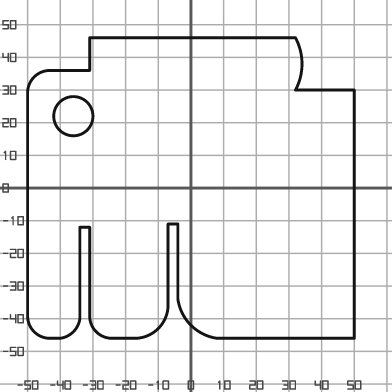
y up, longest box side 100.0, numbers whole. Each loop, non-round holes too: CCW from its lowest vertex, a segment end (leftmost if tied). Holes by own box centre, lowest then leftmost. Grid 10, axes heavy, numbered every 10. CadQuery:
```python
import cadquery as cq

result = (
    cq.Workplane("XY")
    .moveTo(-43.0, -46.0)
    .lineTo(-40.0, -46.0)
    .threePointArc((-36.0, -44.0), (-34.0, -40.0))
    .lineTo(-34.0, -12.0)
    .lineTo(-31.0, -12.0)
    .lineTo(-31.0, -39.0)
    .threePointArc((-29.0, -44.0), (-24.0, -46.0))
    .lineTo(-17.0, -46.0)
    .threePointArc((-10.0, -43.0), (-7.0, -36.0))
    .lineTo(-7.0, -11.0)
    .lineTo(-4.0, -11.0)
    .lineTo(-4.0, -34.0)
    .threePointArc((0.0, -42.0), (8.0, -46.0))
    .lineTo(50.0, -46.0)
    .lineTo(50.0, 30.0)
    .lineTo(32.0, 30.0)
    .threePointArc((34.0, 38.0), (32.0, 46.0))
    .lineTo(-31.0, 46.0)
    .lineTo(-31.0, 36.0)
    .lineTo(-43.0, 36.0)
    .threePointArc((-48.0, 34.0), (-50.0, 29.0))
    .lineTo(-50.0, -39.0)
    .threePointArc((-48.0, -44.0), (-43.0, -46.0))
    .close()
    .moveTo(-36.0, 22.0)
    .circle(6.0)
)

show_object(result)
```